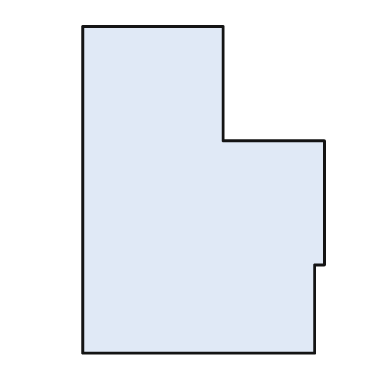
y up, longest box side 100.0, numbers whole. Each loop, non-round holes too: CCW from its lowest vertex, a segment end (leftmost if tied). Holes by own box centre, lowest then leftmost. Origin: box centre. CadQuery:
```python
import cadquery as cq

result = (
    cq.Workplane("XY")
    .moveTo(-37.0, -50.0)
    .lineTo(34.0, -50.0)
    .lineTo(34.0, -23.0)
    .lineTo(37.0, -23.0)
    .lineTo(37.0, 15.0)
    .lineTo(6.0, 15.0)
    .lineTo(6.0, 50.0)
    .lineTo(-37.0, 50.0)
    .close()
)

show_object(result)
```